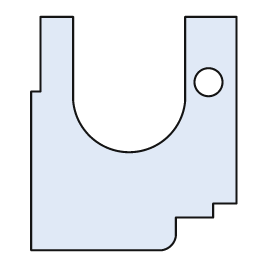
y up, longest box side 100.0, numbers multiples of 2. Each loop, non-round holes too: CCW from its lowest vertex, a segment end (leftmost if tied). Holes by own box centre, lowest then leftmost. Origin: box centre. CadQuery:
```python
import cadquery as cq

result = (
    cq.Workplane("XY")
    .moveTo(-44.0, -50.0)
    .lineTo(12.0, -50.0)
    .threePointArc((16.0, -48.0), (18.0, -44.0))
    .lineTo(18.0, -36.0)
    .lineTo(34.0, -36.0)
    .lineTo(34.0, -30.0)
    .lineTo(44.0, -30.0)
    .lineTo(44.0, 50.0)
    .lineTo(22.0, 50.0)
    .lineTo(22.0, 14.0)
    .threePointArc((-2.0, -8.0), (-26.0, 14.0))
    .lineTo(-26.0, 50.0)
    .lineTo(-40.0, 50.0)
    .lineTo(-40.0, 18.0)
    .lineTo(-44.0, 18.0)
    .close()
    .moveTo(32.0, 22.0)
    .circle(6.0)
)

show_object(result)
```